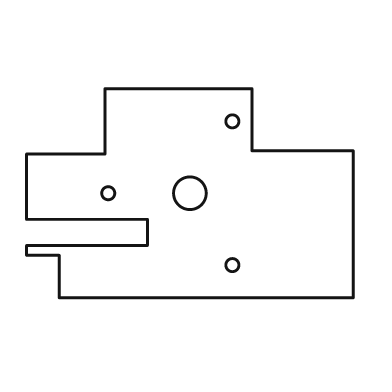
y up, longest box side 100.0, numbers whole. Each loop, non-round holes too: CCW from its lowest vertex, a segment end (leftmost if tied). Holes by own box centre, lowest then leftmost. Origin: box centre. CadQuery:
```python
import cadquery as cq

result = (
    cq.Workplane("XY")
    .moveTo(-40.0, -32.0)
    .lineTo(50.0, -32.0)
    .lineTo(50.0, 13.0)
    .lineTo(19.0, 13.0)
    .lineTo(19.0, 32.0)
    .lineTo(-26.0, 32.0)
    .lineTo(-26.0, 12.0)
    .lineTo(-50.0, 12.0)
    .lineTo(-50.0, -8.0)
    .lineTo(-13.0, -8.0)
    .lineTo(-13.0, -16.0)
    .lineTo(-50.0, -16.0)
    .lineTo(-50.0, -19.0)
    .lineTo(-40.0, -19.0)
    .close()
    .moveTo(13.0, -22.0)
    .circle(2.0)
    .moveTo(-25.0, 0.0)
    .circle(2.0)
    .moveTo(0.0, 0.0)
    .circle(5.0)
    .moveTo(13.0, 22.0)
    .circle(2.0)
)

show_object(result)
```